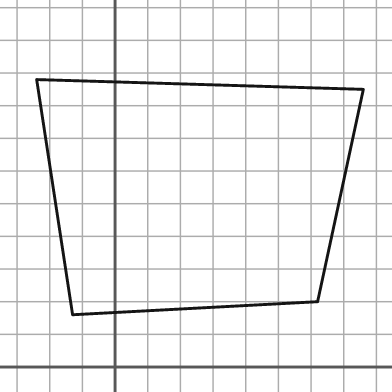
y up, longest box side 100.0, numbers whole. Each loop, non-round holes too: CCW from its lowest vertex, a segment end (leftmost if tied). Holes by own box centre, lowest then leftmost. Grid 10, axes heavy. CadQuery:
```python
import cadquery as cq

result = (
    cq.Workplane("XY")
    .moveTo(-13.0, 16.0)
    .lineTo(62.0, 20.0)
    .lineTo(76.0, 85.0)
    .lineTo(-24.0, 88.0)
    .close()
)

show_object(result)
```